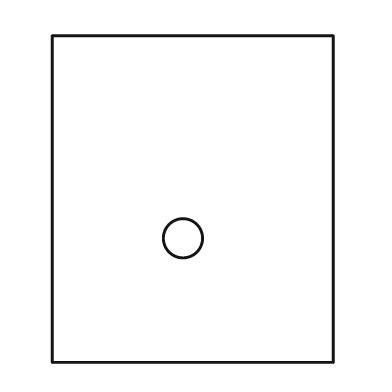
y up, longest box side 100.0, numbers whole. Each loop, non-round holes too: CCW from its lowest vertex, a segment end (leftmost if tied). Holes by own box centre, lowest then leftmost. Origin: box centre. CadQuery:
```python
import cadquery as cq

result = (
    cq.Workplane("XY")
    .moveTo(-43.0, -50.0)
    .lineTo(43.0, -50.0)
    .lineTo(43.0, 50.0)
    .lineTo(-43.0, 50.0)
    .close()
    .moveTo(-3.0, -12.0)
    .circle(6.0)
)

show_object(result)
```